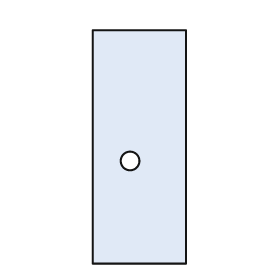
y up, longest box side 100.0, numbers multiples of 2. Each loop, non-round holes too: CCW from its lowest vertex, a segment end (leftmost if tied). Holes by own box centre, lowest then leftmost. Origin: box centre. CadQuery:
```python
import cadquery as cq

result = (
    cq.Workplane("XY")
    .moveTo(-20.0, -50.0)
    .lineTo(20.0, -50.0)
    .lineTo(20.0, 50.0)
    .lineTo(-20.0, 50.0)
    .close()
    .moveTo(-4.0, -6.0)
    .circle(4.0)
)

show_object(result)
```